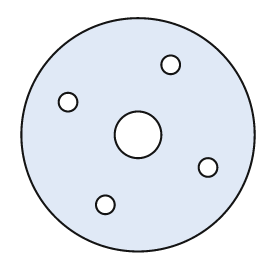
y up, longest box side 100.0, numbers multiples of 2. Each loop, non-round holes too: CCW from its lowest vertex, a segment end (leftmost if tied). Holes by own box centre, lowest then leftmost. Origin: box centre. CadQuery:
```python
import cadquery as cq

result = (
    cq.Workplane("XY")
    .moveTo(0.0, 0.0)
    .circle(50.0)
    .moveTo(-14.0, -30.0)
    .circle(4.0)
    .moveTo(30.0, -14.0)
    .circle(4.0)
    .moveTo(0.0, 0.0)
    .circle(10.0)
    .moveTo(-30.0, 14.0)
    .circle(4.0)
    .moveTo(14.0, 30.0)
    .circle(4.0)
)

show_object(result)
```